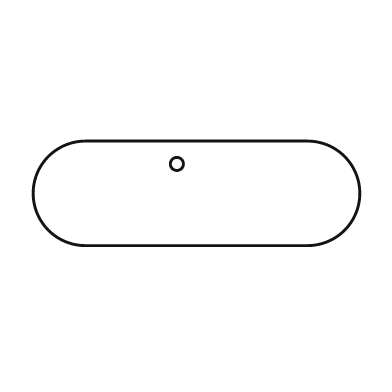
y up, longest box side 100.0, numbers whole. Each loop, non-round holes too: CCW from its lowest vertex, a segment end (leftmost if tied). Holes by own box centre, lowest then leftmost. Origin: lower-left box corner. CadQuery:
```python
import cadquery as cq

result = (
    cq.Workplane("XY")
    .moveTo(16.0, 0.0)
    .lineTo(84.0, 0.0)
    .threePointArc((100.0, 16.0), (84.0, 32.0))
    .lineTo(16.0, 32.0)
    .threePointArc((0.0, 16.0), (16.0, 0.0))
    .close()
    .moveTo(44.0, 25.0)
    .circle(2.0)
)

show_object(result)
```